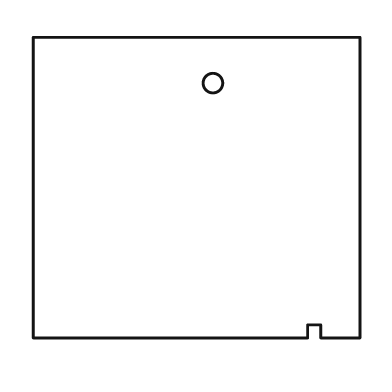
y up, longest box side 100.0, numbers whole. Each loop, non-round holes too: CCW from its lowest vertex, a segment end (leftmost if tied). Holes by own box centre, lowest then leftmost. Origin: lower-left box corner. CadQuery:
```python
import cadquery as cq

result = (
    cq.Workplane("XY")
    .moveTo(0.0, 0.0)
    .lineTo(84.0, 0.0)
    .lineTo(84.0, 4.0)
    .lineTo(88.0, 4.0)
    .lineTo(88.0, 0.0)
    .lineTo(100.0, 0.0)
    .lineTo(100.0, 92.0)
    .lineTo(0.0, 92.0)
    .close()
    .moveTo(55.0, 78.0)
    .circle(3.0)
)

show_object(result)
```